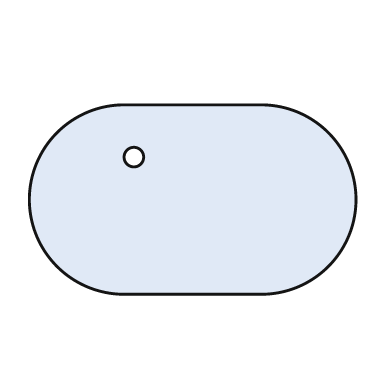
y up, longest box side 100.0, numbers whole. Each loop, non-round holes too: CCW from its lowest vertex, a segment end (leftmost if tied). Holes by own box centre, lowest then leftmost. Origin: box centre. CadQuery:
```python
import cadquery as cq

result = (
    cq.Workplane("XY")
    .moveTo(-21.0, -29.0)
    .lineTo(21.0, -29.0)
    .threePointArc((50.0, 0.0), (21.0, 29.0))
    .lineTo(-21.0, 29.0)
    .threePointArc((-50.0, 0.0), (-21.0, -29.0))
    .close()
    .moveTo(-18.0, 13.0)
    .circle(3.0)
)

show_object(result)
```